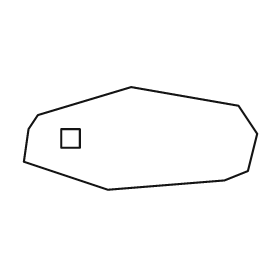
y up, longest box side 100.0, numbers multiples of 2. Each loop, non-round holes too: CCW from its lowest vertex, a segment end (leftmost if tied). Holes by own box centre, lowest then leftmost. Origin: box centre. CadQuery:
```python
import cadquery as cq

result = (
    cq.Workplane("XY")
    .moveTo(-14.0, -22.0)
    .lineTo(36.0, -18.0)
    .lineTo(46.0, -14.0)
    .lineTo(50.0, 2.0)
    .lineTo(42.0, 14.0)
    .lineTo(-4.0, 22.0)
    .lineTo(-44.0, 10.0)
    .lineTo(-48.0, 4.0)
    .lineTo(-50.0, -10.0)
    .close()
    .moveTo(-34.0, -4.0)
    .lineTo(-26.0, -4.0)
    .lineTo(-26.0, 4.0)
    .lineTo(-34.0, 4.0)
    .close()
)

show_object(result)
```